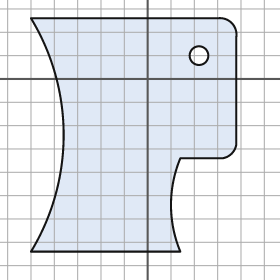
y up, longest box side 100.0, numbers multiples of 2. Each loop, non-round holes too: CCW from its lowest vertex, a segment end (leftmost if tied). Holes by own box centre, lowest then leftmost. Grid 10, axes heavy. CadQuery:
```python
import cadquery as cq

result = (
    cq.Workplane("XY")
    .moveTo(-50.0, -74.0)
    .lineTo(14.0, -74.0)
    .threePointArc((10.0, -54.0), (14.0, -34.0))
    .lineTo(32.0, -34.0)
    .threePointArc((36.0, -32.0), (38.0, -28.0))
    .lineTo(38.0, 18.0)
    .threePointArc((36.0, 24.0), (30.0, 26.0))
    .lineTo(-50.0, 26.0)
    .threePointArc((-36.0, -24.0), (-50.0, -74.0))
    .close()
    .moveTo(22.0, 10.0)
    .circle(4.0)
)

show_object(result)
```